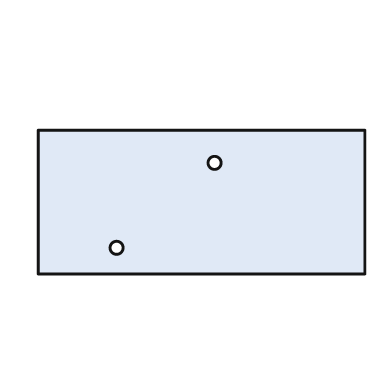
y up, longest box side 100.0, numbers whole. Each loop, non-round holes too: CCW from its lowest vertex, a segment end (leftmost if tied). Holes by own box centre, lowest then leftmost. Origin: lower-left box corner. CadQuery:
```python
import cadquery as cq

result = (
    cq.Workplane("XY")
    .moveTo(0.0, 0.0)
    .lineTo(100.0, 0.0)
    .lineTo(100.0, 44.0)
    .lineTo(0.0, 44.0)
    .close()
    .moveTo(24.0, 8.0)
    .circle(2.0)
    .moveTo(54.0, 34.0)
    .circle(2.0)
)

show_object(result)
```